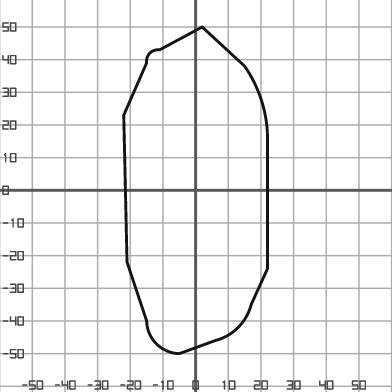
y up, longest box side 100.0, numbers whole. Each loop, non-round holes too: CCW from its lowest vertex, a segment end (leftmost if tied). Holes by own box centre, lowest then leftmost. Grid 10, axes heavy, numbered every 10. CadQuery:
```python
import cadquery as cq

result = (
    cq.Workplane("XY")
    .moveTo(-5.0, -50.0)
    .lineTo(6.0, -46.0)
    .threePointArc((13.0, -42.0), (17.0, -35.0))
    .lineTo(22.0, -24.0)
    .lineTo(22.0, 17.0)
    .threePointArc((20.0, 28.0), (15.0, 38.0))
    .lineTo(2.0, 50.0)
    .lineTo(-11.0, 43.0)
    .threePointArc((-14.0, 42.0), (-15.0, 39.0))
    .lineTo(-22.0, 23.0)
    .lineTo(-21.0, -22.0)
    .lineTo(-15.0, -40.0)
    .threePointArc((-12.0, -47.0), (-5.0, -50.0))
    .close()
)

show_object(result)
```